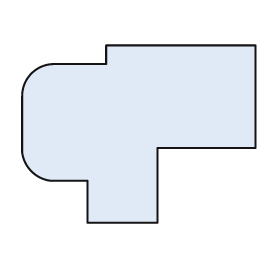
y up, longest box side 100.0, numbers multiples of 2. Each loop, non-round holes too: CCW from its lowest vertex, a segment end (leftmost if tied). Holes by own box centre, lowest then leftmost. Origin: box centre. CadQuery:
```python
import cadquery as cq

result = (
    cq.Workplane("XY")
    .moveTo(-22.0, -38.0)
    .lineTo(8.0, -38.0)
    .lineTo(8.0, -6.0)
    .lineTo(50.0, -6.0)
    .lineTo(50.0, 38.0)
    .lineTo(-14.0, 38.0)
    .lineTo(-14.0, 30.0)
    .lineTo(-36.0, 30.0)
    .threePointArc((-46.0, 26.0), (-50.0, 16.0))
    .lineTo(-50.0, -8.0)
    .threePointArc((-46.0, -16.0), (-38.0, -20.0))
    .lineTo(-22.0, -20.0)
    .close()
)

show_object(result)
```